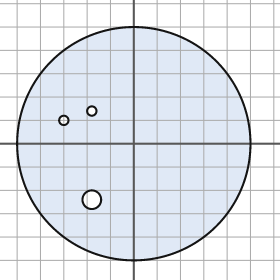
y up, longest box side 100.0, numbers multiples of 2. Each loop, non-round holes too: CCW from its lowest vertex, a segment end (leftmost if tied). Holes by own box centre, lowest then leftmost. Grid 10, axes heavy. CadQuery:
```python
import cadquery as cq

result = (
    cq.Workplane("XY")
    .moveTo(0.0, 0.0)
    .circle(50.0)
    .moveTo(-18.0, -24.0)
    .circle(4.0)
    .moveTo(-30.0, 10.0)
    .circle(2.0)
    .moveTo(-18.0, 14.0)
    .circle(2.0)
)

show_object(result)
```